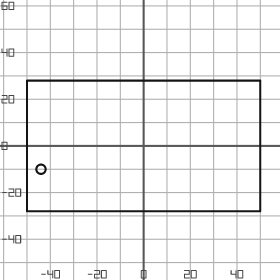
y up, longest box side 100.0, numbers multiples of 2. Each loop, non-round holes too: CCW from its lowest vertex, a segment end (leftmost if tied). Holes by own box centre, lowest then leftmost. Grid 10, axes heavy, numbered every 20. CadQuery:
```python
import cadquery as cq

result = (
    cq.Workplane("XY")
    .moveTo(-50.0, -28.0)
    .lineTo(50.0, -28.0)
    .lineTo(50.0, 28.0)
    .lineTo(-50.0, 28.0)
    .close()
    .moveTo(-44.0, -10.0)
    .circle(2.0)
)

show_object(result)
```